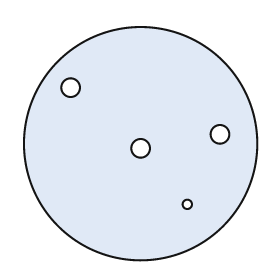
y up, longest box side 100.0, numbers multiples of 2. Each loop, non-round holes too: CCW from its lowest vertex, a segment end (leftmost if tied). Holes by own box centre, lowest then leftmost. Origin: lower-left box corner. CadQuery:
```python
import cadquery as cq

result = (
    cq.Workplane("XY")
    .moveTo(50.0, 50.0)
    .circle(50.0)
    .moveTo(70.0, 24.0)
    .circle(2.0)
    .moveTo(50.0, 48.0)
    .circle(4.0)
    .moveTo(84.0, 54.0)
    .circle(4.0)
    .moveTo(20.0, 74.0)
    .circle(4.0)
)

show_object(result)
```